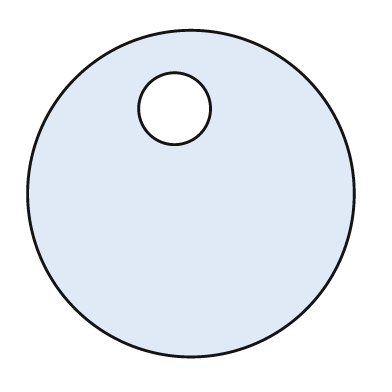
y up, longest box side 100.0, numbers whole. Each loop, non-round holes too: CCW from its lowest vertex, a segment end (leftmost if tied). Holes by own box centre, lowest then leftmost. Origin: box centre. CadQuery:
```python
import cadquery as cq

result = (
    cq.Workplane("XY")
    .moveTo(0.0, 0.0)
    .circle(50.0)
    .moveTo(-5.0, 26.0)
    .circle(11.0)
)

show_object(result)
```